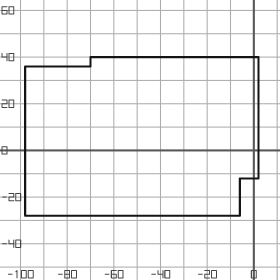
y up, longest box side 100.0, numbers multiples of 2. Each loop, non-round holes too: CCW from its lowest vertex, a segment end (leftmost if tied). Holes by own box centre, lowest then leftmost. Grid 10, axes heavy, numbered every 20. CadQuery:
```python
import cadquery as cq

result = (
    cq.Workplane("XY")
    .moveTo(-98.0, -28.0)
    .lineTo(-6.0, -28.0)
    .lineTo(-6.0, -12.0)
    .lineTo(2.0, -12.0)
    .lineTo(2.0, 40.0)
    .lineTo(-70.0, 40.0)
    .lineTo(-70.0, 36.0)
    .lineTo(-98.0, 36.0)
    .close()
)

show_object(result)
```